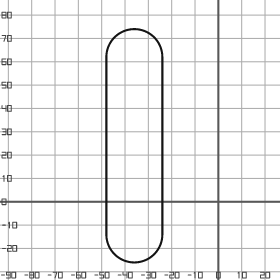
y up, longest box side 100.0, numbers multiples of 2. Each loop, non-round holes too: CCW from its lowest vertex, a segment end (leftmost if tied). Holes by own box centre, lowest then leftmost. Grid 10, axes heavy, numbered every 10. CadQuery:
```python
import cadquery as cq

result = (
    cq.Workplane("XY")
    .moveTo(-48.0, -14.0)
    .threePointArc((-36.0, -26.0), (-24.0, -14.0))
    .lineTo(-24.0, 62.0)
    .threePointArc((-36.0, 74.0), (-48.0, 62.0))
    .close()
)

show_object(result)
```